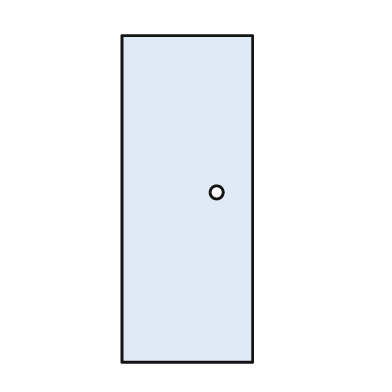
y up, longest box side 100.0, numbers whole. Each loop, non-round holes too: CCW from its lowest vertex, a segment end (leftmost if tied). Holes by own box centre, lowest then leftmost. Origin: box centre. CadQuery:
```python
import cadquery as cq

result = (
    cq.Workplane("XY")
    .moveTo(-20.0, -50.0)
    .lineTo(20.0, -50.0)
    .lineTo(20.0, 50.0)
    .lineTo(-20.0, 50.0)
    .close()
    .moveTo(9.0, 2.0)
    .circle(2.0)
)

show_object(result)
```